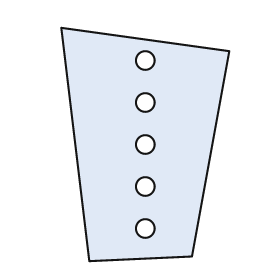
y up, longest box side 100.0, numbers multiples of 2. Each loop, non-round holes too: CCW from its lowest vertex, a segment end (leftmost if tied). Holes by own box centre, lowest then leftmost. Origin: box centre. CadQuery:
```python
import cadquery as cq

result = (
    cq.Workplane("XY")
    .moveTo(-24.0, -50.0)
    .lineTo(20.0, -48.0)
    .lineTo(36.0, 40.0)
    .lineTo(-36.0, 50.0)
    .close()
    .moveTo(0.0, -36.0)
    .circle(4.0)
    .moveTo(0.0, -18.0)
    .circle(4.0)
    .moveTo(0.0, 0.0)
    .circle(4.0)
    .moveTo(0.0, 18.0)
    .circle(4.0)
    .moveTo(0.0, 36.0)
    .circle(4.0)
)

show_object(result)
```